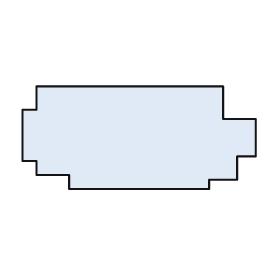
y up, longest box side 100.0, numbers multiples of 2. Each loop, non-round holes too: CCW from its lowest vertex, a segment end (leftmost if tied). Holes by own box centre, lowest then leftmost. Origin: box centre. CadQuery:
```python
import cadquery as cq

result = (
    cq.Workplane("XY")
    .moveTo(-30.0, -22.0)
    .lineTo(30.0, -22.0)
    .lineTo(30.0, -18.0)
    .lineTo(42.0, -18.0)
    .lineTo(42.0, -8.0)
    .lineTo(50.0, -8.0)
    .lineTo(50.0, 8.0)
    .lineTo(36.0, 8.0)
    .lineTo(36.0, 22.0)
    .lineTo(-44.0, 22.0)
    .lineTo(-44.0, 12.0)
    .lineTo(-50.0, 12.0)
    .lineTo(-50.0, -10.0)
    .lineTo(-44.0, -10.0)
    .lineTo(-44.0, -16.0)
    .lineTo(-30.0, -16.0)
    .close()
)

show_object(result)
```